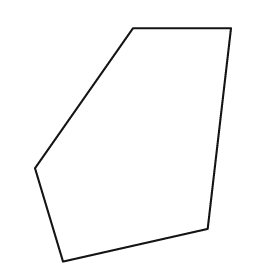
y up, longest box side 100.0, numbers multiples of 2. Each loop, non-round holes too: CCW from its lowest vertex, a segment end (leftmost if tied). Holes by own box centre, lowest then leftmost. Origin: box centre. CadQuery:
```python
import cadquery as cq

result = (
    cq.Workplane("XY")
    .moveTo(-30.0, -50.0)
    .lineTo(32.0, -36.0)
    .lineTo(42.0, 50.0)
    .lineTo(0.0, 50.0)
    .lineTo(-42.0, -10.0)
    .close()
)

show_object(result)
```